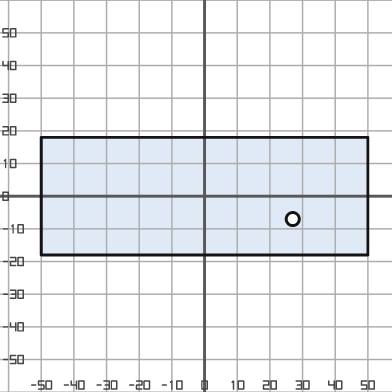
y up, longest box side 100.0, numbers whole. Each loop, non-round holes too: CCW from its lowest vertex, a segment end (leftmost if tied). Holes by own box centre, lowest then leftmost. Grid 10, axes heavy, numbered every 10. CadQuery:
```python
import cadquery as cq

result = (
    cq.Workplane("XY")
    .moveTo(-50.0, -18.0)
    .lineTo(50.0, -18.0)
    .lineTo(50.0, 18.0)
    .lineTo(-50.0, 18.0)
    .close()
    .moveTo(27.0, -7.0)
    .circle(2.0)
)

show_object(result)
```